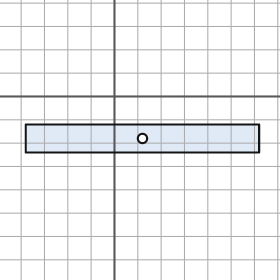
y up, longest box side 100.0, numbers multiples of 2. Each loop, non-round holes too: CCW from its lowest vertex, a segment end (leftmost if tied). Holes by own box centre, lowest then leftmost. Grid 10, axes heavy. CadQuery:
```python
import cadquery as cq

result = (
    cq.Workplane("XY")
    .moveTo(-38.0, -24.0)
    .lineTo(62.0, -24.0)
    .lineTo(62.0, -12.0)
    .lineTo(-38.0, -12.0)
    .close()
    .moveTo(12.0, -18.0)
    .circle(2.0)
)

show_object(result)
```